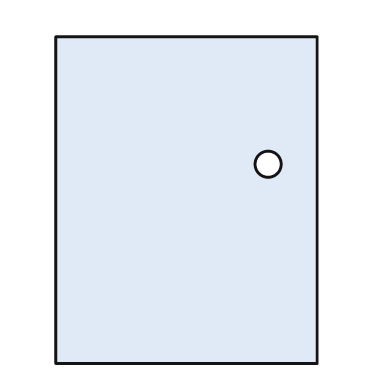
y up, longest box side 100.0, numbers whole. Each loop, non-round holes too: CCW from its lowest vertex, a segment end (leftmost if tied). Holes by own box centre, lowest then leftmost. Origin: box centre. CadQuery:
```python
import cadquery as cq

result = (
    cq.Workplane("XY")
    .moveTo(-40.0, -50.0)
    .lineTo(40.0, -50.0)
    .lineTo(40.0, 50.0)
    .lineTo(-40.0, 50.0)
    .close()
    .moveTo(25.0, 11.0)
    .circle(4.0)
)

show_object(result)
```